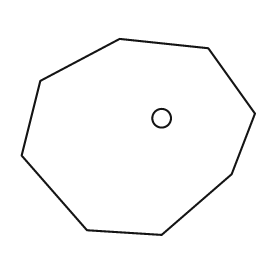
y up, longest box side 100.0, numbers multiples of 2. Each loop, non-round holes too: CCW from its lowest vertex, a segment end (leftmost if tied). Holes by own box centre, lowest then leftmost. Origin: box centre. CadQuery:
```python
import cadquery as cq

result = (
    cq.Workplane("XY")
    .moveTo(10.0, -42.0)
    .lineTo(40.0, -16.0)
    .lineTo(50.0, 10.0)
    .lineTo(30.0, 38.0)
    .lineTo(-8.0, 42.0)
    .lineTo(-42.0, 24.0)
    .lineTo(-50.0, -8.0)
    .lineTo(-22.0, -40.0)
    .close()
    .moveTo(10.0, 8.0)
    .circle(4.0)
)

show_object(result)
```